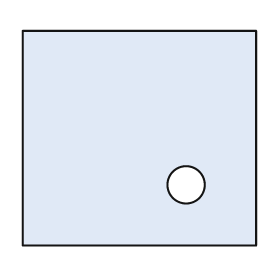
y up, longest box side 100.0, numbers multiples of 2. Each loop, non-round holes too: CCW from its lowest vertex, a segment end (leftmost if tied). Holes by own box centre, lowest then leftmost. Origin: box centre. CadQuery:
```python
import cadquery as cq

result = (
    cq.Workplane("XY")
    .moveTo(-50.0, -46.0)
    .lineTo(50.0, -46.0)
    .lineTo(50.0, 46.0)
    .lineTo(-50.0, 46.0)
    .close()
    .moveTo(20.0, -20.0)
    .circle(8.0)
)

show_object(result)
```